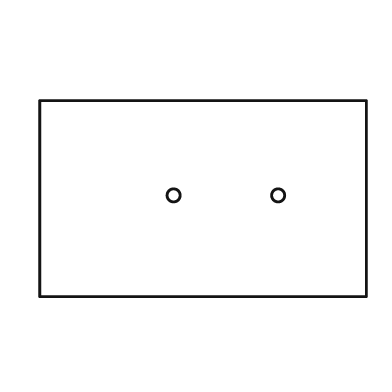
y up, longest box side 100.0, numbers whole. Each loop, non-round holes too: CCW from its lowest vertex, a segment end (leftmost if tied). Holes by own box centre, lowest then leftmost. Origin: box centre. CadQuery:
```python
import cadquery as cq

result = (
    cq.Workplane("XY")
    .moveTo(-50.0, -30.0)
    .lineTo(50.0, -30.0)
    .lineTo(50.0, 30.0)
    .lineTo(-50.0, 30.0)
    .close()
    .moveTo(-9.0, 1.0)
    .circle(2.0)
    .moveTo(23.0, 1.0)
    .circle(2.0)
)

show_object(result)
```